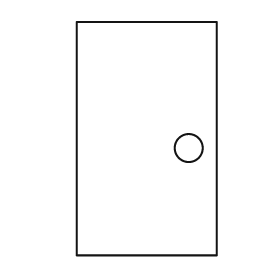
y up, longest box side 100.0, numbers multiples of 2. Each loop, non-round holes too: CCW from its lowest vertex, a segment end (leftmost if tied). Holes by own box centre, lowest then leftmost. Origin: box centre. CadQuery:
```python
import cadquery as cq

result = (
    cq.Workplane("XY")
    .moveTo(-30.0, -50.0)
    .lineTo(30.0, -50.0)
    .lineTo(30.0, 50.0)
    .lineTo(-30.0, 50.0)
    .close()
    .moveTo(18.0, -4.0)
    .circle(6.0)
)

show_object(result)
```